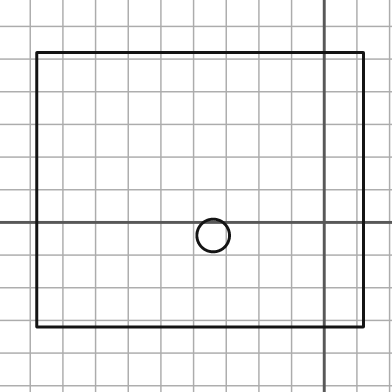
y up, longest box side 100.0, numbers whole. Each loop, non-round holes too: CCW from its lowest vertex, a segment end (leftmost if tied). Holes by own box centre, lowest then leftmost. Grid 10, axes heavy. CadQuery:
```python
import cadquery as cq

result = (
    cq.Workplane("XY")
    .moveTo(-88.0, -32.0)
    .lineTo(12.0, -32.0)
    .lineTo(12.0, 52.0)
    .lineTo(-88.0, 52.0)
    .close()
    .moveTo(-34.0, -4.0)
    .circle(5.0)
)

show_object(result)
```